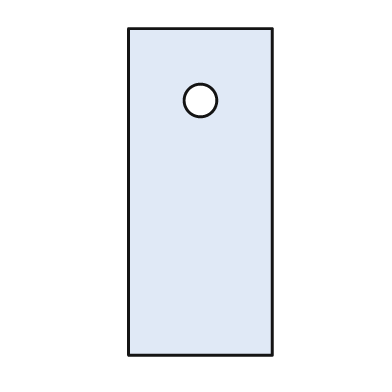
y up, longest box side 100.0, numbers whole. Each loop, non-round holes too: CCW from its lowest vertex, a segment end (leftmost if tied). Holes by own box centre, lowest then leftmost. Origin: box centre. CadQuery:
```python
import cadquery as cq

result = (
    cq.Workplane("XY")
    .moveTo(-22.0, -50.0)
    .lineTo(22.0, -50.0)
    .lineTo(22.0, 50.0)
    .lineTo(-22.0, 50.0)
    .close()
    .moveTo(0.0, 28.0)
    .circle(5.0)
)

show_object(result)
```